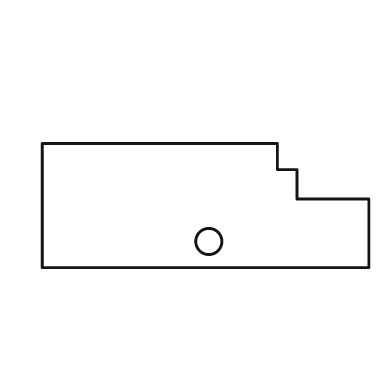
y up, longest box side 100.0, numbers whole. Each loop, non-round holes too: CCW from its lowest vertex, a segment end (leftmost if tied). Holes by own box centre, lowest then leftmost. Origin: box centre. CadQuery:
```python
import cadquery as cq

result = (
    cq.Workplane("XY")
    .moveTo(-50.0, -19.0)
    .lineTo(50.0, -19.0)
    .lineTo(50.0, 2.0)
    .lineTo(28.0, 2.0)
    .lineTo(28.0, 11.0)
    .lineTo(22.0, 11.0)
    .lineTo(22.0, 19.0)
    .lineTo(-50.0, 19.0)
    .close()
    .moveTo(1.0, -11.0)
    .circle(4.0)
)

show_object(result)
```